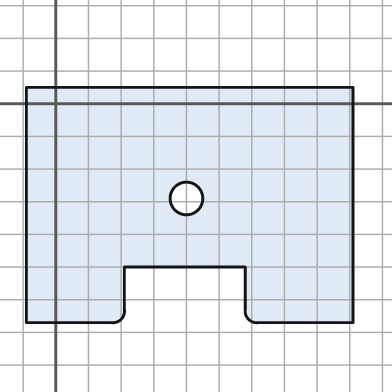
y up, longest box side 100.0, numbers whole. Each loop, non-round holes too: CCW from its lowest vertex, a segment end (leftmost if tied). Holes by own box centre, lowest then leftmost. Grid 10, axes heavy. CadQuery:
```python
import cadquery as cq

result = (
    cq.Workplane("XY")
    .moveTo(-9.0, -67.0)
    .lineTo(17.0, -67.0)
    .threePointArc((20.0, -66.0), (21.0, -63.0))
    .lineTo(21.0, -50.0)
    .lineTo(58.0, -50.0)
    .lineTo(58.0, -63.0)
    .threePointArc((59.0, -66.0), (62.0, -67.0))
    .lineTo(91.0, -67.0)
    .lineTo(91.0, 5.0)
    .lineTo(-9.0, 5.0)
    .close()
    .moveTo(40.0, -29.0)
    .circle(5.0)
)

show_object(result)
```